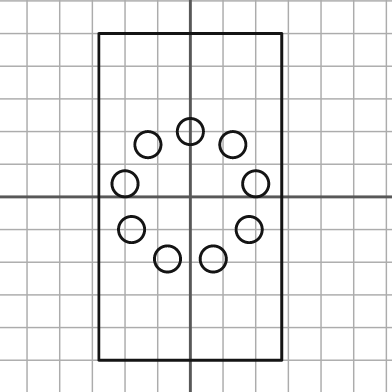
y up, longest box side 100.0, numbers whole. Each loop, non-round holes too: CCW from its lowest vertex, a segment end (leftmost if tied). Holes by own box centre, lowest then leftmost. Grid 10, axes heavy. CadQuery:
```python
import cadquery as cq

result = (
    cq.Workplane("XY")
    .moveTo(-28.0, -50.0)
    .lineTo(28.0, -50.0)
    .lineTo(28.0, 50.0)
    .lineTo(-28.0, 50.0)
    .close()
    .moveTo(-7.0, -19.0)
    .circle(4.0)
    .moveTo(7.0, -19.0)
    .circle(4.0)
    .moveTo(-18.0, -10.0)
    .circle(4.0)
    .moveTo(18.0, -10.0)
    .circle(4.0)
    .moveTo(-20.0, 4.0)
    .circle(4.0)
    .moveTo(20.0, 4.0)
    .circle(4.0)
    .moveTo(-13.0, 16.0)
    .circle(4.0)
    .moveTo(13.0, 16.0)
    .circle(4.0)
    .moveTo(0.0, 20.0)
    .circle(4.0)
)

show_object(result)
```